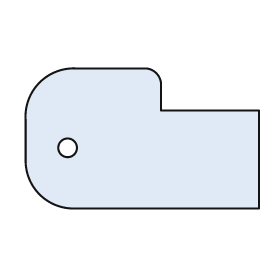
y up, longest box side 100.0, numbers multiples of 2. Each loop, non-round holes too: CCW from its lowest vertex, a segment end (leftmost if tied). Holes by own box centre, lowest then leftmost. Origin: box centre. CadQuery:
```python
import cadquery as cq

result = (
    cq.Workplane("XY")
    .moveTo(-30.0, -30.0)
    .lineTo(50.0, -30.0)
    .lineTo(50.0, 12.0)
    .lineTo(8.0, 12.0)
    .lineTo(8.0, 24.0)
    .threePointArc((6.0, 28.0), (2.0, 30.0))
    .lineTo(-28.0, 30.0)
    .threePointArc((-44.0, 24.0), (-50.0, 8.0))
    .lineTo(-50.0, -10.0)
    .threePointArc((-44.0, -24.0), (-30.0, -30.0))
    .close()
    .moveTo(-32.0, -4.0)
    .circle(4.0)
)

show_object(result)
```